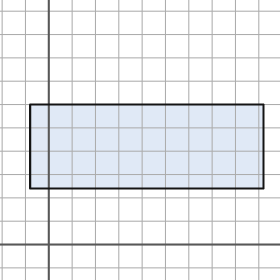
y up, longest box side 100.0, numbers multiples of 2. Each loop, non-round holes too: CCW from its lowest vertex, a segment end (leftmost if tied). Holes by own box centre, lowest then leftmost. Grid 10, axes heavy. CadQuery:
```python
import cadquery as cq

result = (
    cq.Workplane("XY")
    .moveTo(-8.0, 24.0)
    .lineTo(92.0, 24.0)
    .lineTo(92.0, 60.0)
    .lineTo(-8.0, 60.0)
    .close()
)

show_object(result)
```